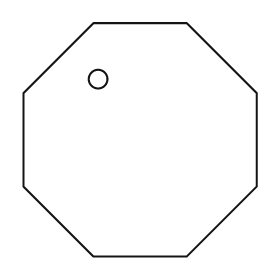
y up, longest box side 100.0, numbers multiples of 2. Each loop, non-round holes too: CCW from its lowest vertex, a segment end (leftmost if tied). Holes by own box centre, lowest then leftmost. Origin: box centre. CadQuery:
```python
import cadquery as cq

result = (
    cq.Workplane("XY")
    .moveTo(-20.0, -50.0)
    .lineTo(20.0, -50.0)
    .lineTo(50.0, -20.0)
    .lineTo(50.0, 20.0)
    .lineTo(20.0, 50.0)
    .lineTo(-20.0, 50.0)
    .lineTo(-50.0, 20.0)
    .lineTo(-50.0, -20.0)
    .close()
    .moveTo(-18.0, 26.0)
    .circle(4.0)
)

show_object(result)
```